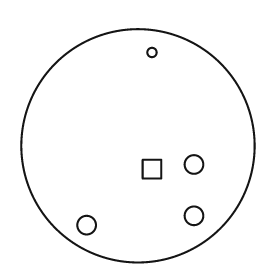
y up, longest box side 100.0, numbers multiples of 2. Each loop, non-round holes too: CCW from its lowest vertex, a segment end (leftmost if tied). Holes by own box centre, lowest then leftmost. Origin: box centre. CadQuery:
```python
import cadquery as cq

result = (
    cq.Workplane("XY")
    .moveTo(0.0, 0.0)
    .circle(50.0)
    .moveTo(-22.0, -34.0)
    .circle(4.0)
    .moveTo(24.0, -30.0)
    .circle(4.0)
    .moveTo(2.0, -14.0)
    .lineTo(10.0, -14.0)
    .lineTo(10.0, -6.0)
    .lineTo(2.0, -6.0)
    .close()
    .moveTo(24.0, -8.0)
    .circle(4.0)
    .moveTo(6.0, 40.0)
    .circle(2.0)
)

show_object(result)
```